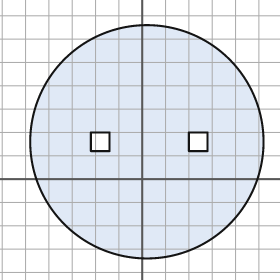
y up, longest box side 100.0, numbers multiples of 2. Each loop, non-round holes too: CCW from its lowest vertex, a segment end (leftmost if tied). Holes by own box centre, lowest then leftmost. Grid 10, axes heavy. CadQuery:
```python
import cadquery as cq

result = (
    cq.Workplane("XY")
    .moveTo(2.0, 16.0)
    .circle(50.0)
    .moveTo(-22.0, 12.0)
    .lineTo(-14.0, 12.0)
    .lineTo(-14.0, 20.0)
    .lineTo(-22.0, 20.0)
    .close()
    .moveTo(20.0, 12.0)
    .lineTo(28.0, 12.0)
    .lineTo(28.0, 20.0)
    .lineTo(20.0, 20.0)
    .close()
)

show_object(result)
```